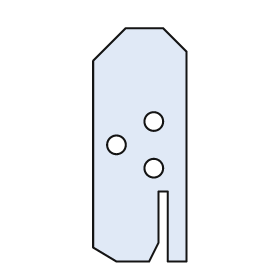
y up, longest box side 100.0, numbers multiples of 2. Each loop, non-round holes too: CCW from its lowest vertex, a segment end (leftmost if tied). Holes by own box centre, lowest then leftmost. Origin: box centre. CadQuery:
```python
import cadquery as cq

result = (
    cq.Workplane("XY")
    .moveTo(-10.0, -50.0)
    .lineTo(4.0, -50.0)
    .lineTo(8.0, -42.0)
    .lineTo(8.0, -20.0)
    .lineTo(12.0, -20.0)
    .lineTo(12.0, -50.0)
    .lineTo(20.0, -50.0)
    .lineTo(20.0, 40.0)
    .lineTo(10.0, 50.0)
    .lineTo(-6.0, 50.0)
    .lineTo(-20.0, 36.0)
    .lineTo(-20.0, -44.0)
    .close()
    .moveTo(6.0, -10.0)
    .circle(4.0)
    .moveTo(-10.0, 0.0)
    .circle(4.0)
    .moveTo(6.0, 10.0)
    .circle(4.0)
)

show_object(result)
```